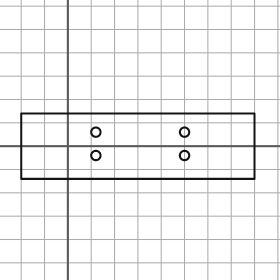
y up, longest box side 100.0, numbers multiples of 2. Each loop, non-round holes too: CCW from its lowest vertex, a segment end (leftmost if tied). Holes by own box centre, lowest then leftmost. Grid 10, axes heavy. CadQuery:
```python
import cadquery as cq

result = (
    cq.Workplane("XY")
    .moveTo(-20.0, -14.0)
    .lineTo(80.0, -14.0)
    .lineTo(80.0, 14.0)
    .lineTo(-20.0, 14.0)
    .close()
    .moveTo(12.0, -4.0)
    .circle(2.0)
    .moveTo(50.0, -4.0)
    .circle(2.0)
    .moveTo(12.0, 6.0)
    .circle(2.0)
    .moveTo(50.0, 6.0)
    .circle(2.0)
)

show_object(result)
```